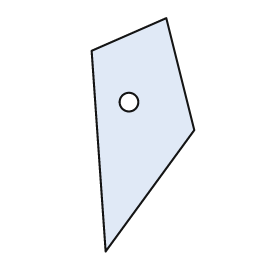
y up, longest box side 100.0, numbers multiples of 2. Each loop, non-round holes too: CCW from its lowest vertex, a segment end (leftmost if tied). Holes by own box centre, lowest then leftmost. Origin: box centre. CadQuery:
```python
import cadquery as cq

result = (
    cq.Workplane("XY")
    .moveTo(-16.0, -50.0)
    .lineTo(22.0, 2.0)
    .lineTo(10.0, 50.0)
    .lineTo(-22.0, 36.0)
    .close()
    .moveTo(-6.0, 14.0)
    .circle(4.0)
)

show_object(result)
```